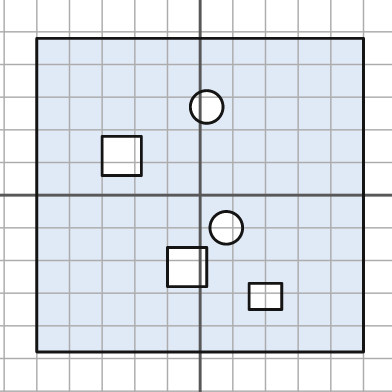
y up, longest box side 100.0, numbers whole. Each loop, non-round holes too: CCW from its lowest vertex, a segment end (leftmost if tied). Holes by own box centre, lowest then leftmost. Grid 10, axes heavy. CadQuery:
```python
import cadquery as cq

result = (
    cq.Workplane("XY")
    .moveTo(-50.0, -48.0)
    .lineTo(50.0, -48.0)
    .lineTo(50.0, 48.0)
    .lineTo(-50.0, 48.0)
    .close()
    .moveTo(15.0, -35.0)
    .lineTo(25.0, -35.0)
    .lineTo(25.0, -27.0)
    .lineTo(15.0, -27.0)
    .close()
    .moveTo(-10.0, -28.0)
    .lineTo(2.0, -28.0)
    .lineTo(2.0, -16.0)
    .lineTo(-10.0, -16.0)
    .close()
    .moveTo(8.0, -10.0)
    .circle(5.0)
    .moveTo(-30.0, 6.0)
    .lineTo(-18.0, 6.0)
    .lineTo(-18.0, 18.0)
    .lineTo(-30.0, 18.0)
    .close()
    .moveTo(2.0, 27.0)
    .circle(5.0)
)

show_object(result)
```